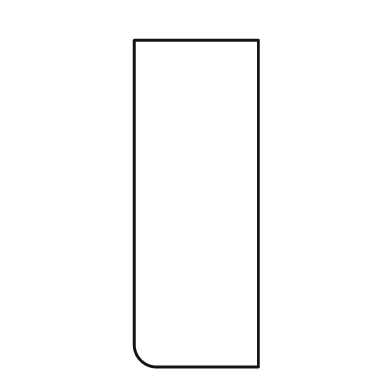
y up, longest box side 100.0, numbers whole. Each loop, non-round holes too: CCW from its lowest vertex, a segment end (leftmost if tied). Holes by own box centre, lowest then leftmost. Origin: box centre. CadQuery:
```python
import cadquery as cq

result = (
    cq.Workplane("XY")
    .moveTo(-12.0, -50.0)
    .lineTo(19.0, -50.0)
    .lineTo(19.0, 50.0)
    .lineTo(-19.0, 50.0)
    .lineTo(-19.0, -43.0)
    .threePointArc((-17.0, -48.0), (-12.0, -50.0))
    .close()
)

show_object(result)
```